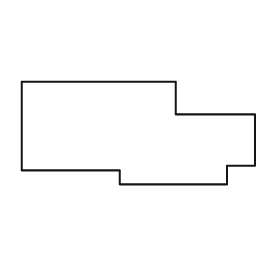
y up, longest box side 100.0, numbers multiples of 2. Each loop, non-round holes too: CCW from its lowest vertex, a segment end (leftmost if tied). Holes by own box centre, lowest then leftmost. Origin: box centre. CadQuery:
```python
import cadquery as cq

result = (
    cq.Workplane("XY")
    .moveTo(-8.0, -22.0)
    .lineTo(38.0, -22.0)
    .lineTo(38.0, -14.0)
    .lineTo(50.0, -14.0)
    .lineTo(50.0, 8.0)
    .lineTo(16.0, 8.0)
    .lineTo(16.0, 22.0)
    .lineTo(-50.0, 22.0)
    .lineTo(-50.0, -16.0)
    .lineTo(-8.0, -16.0)
    .close()
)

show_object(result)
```